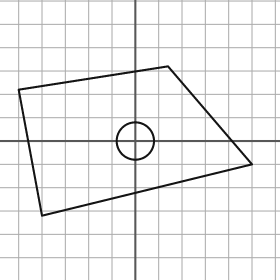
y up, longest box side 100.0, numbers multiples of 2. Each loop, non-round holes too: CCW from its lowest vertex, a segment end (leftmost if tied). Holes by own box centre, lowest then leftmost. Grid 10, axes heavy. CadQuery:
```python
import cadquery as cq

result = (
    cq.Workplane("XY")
    .moveTo(-40.0, -32.0)
    .lineTo(50.0, -10.0)
    .lineTo(14.0, 32.0)
    .lineTo(-50.0, 22.0)
    .close()
    .moveTo(0.0, 0.0)
    .circle(8.0)
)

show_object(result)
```